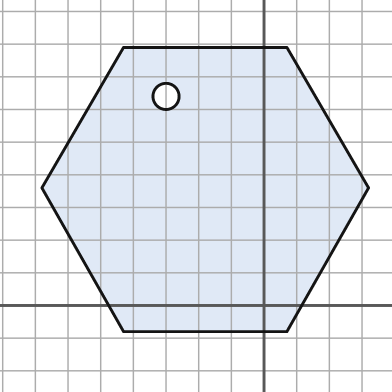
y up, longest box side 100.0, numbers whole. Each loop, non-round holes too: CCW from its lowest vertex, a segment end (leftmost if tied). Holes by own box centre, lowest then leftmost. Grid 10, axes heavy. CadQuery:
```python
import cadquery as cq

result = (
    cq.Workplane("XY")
    .moveTo(-43.0, -8.0)
    .lineTo(7.0, -8.0)
    .lineTo(32.0, 36.0)
    .lineTo(7.0, 79.0)
    .lineTo(-43.0, 79.0)
    .lineTo(-68.0, 36.0)
    .close()
    .moveTo(-30.0, 64.0)
    .circle(4.0)
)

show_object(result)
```